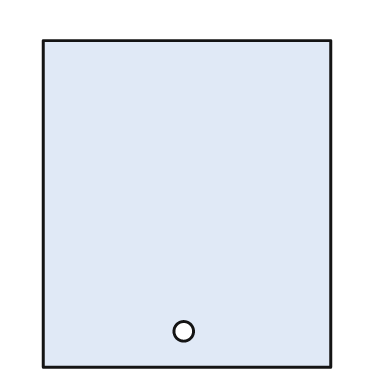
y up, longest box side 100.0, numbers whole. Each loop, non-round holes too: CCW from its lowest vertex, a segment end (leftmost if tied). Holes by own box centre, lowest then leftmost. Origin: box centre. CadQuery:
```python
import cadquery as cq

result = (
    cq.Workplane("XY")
    .moveTo(-44.0, -50.0)
    .lineTo(44.0, -50.0)
    .lineTo(44.0, 50.0)
    .lineTo(-44.0, 50.0)
    .close()
    .moveTo(-1.0, -39.0)
    .circle(3.0)
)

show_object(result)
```